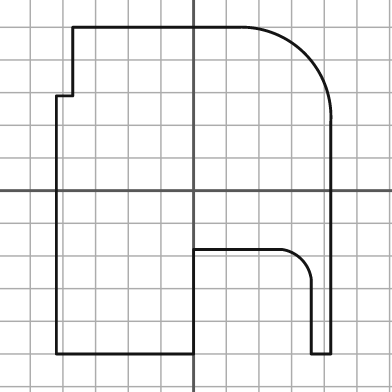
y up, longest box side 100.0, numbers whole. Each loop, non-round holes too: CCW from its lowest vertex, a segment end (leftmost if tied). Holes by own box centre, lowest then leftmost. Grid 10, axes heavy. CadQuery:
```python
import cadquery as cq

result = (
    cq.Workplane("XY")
    .moveTo(-42.0, -50.0)
    .lineTo(0.0, -50.0)
    .lineTo(0.0, -18.0)
    .lineTo(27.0, -18.0)
    .threePointArc((33.0, -21.0), (36.0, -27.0))
    .lineTo(36.0, -50.0)
    .lineTo(42.0, -50.0)
    .lineTo(42.0, 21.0)
    .threePointArc((34.0, 42.0), (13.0, 50.0))
    .lineTo(-37.0, 50.0)
    .lineTo(-37.0, 29.0)
    .lineTo(-42.0, 29.0)
    .close()
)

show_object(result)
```